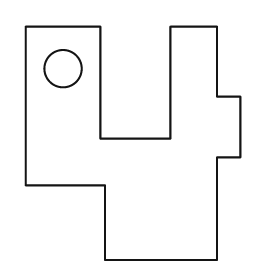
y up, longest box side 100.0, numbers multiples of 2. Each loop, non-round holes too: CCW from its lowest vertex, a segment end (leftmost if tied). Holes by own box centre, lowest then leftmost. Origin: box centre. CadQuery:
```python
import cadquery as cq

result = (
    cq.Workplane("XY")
    .moveTo(-12.0, -50.0)
    .lineTo(36.0, -50.0)
    .lineTo(36.0, -6.0)
    .lineTo(46.0, -6.0)
    .lineTo(46.0, 20.0)
    .lineTo(36.0, 20.0)
    .lineTo(36.0, 50.0)
    .lineTo(16.0, 50.0)
    .lineTo(16.0, 2.0)
    .lineTo(-14.0, 2.0)
    .lineTo(-14.0, 50.0)
    .lineTo(-46.0, 50.0)
    .lineTo(-46.0, -18.0)
    .lineTo(-12.0, -18.0)
    .close()
    .moveTo(-30.0, 32.0)
    .circle(8.0)
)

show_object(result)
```